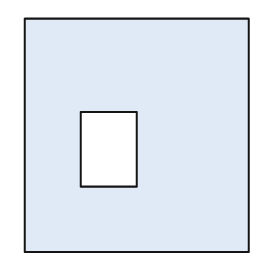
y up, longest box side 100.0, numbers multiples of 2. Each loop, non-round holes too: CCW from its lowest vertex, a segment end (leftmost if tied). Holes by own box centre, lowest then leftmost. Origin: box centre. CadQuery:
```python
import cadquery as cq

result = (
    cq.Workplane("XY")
    .moveTo(-48.0, -50.0)
    .lineTo(48.0, -50.0)
    .lineTo(48.0, 50.0)
    .lineTo(-48.0, 50.0)
    .close()
    .moveTo(-24.0, -22.0)
    .lineTo(0.0, -22.0)
    .lineTo(0.0, 10.0)
    .lineTo(-24.0, 10.0)
    .close()
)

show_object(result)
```